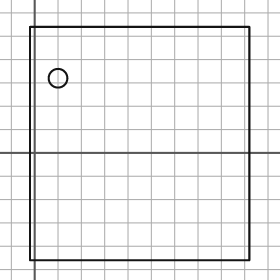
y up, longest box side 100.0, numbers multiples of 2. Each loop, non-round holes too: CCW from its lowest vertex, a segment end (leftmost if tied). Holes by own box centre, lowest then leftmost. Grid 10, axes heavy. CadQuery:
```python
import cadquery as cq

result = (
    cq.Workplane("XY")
    .moveTo(-2.0, -46.0)
    .lineTo(92.0, -46.0)
    .lineTo(92.0, 54.0)
    .lineTo(-2.0, 54.0)
    .close()
    .moveTo(10.0, 32.0)
    .circle(4.0)
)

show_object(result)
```